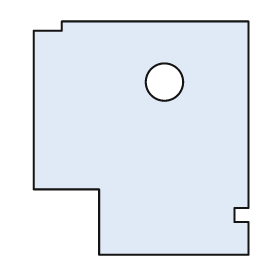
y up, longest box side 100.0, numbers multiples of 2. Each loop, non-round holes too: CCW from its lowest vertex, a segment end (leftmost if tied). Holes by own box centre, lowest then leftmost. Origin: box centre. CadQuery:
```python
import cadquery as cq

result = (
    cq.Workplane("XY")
    .moveTo(-18.0, -50.0)
    .lineTo(46.0, -50.0)
    .lineTo(46.0, -36.0)
    .lineTo(40.0, -36.0)
    .lineTo(40.0, -30.0)
    .lineTo(46.0, -30.0)
    .lineTo(46.0, 50.0)
    .lineTo(-34.0, 50.0)
    .lineTo(-34.0, 46.0)
    .lineTo(-46.0, 46.0)
    .lineTo(-46.0, -22.0)
    .lineTo(-18.0, -22.0)
    .close()
    .moveTo(10.0, 24.0)
    .circle(8.0)
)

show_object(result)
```